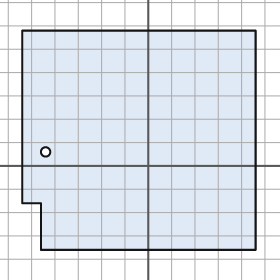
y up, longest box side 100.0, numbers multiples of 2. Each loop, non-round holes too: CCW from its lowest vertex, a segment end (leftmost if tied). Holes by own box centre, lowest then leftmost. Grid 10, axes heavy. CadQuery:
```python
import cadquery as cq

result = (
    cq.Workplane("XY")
    .moveTo(-46.0, -36.0)
    .lineTo(46.0, -36.0)
    .lineTo(46.0, 58.0)
    .lineTo(-54.0, 58.0)
    .lineTo(-54.0, -16.0)
    .lineTo(-46.0, -16.0)
    .close()
    .moveTo(-44.0, 6.0)
    .circle(2.0)
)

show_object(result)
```